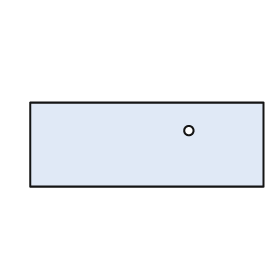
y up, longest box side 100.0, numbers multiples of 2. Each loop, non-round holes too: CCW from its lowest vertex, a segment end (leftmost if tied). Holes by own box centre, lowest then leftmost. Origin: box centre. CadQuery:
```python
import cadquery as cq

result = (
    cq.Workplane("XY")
    .moveTo(-50.0, -18.0)
    .lineTo(50.0, -18.0)
    .lineTo(50.0, 18.0)
    .lineTo(-50.0, 18.0)
    .close()
    .moveTo(18.0, 6.0)
    .circle(2.0)
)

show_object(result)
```